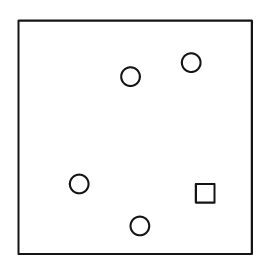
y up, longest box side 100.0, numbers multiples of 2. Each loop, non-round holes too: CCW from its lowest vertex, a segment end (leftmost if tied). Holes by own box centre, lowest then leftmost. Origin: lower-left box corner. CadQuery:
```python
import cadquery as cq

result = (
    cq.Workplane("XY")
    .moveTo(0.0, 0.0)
    .lineTo(100.0, 0.0)
    .lineTo(100.0, 100.0)
    .lineTo(0.0, 100.0)
    .close()
    .moveTo(52.0, 12.0)
    .circle(4.0)
    .moveTo(76.0, 22.0)
    .lineTo(84.0, 22.0)
    .lineTo(84.0, 30.0)
    .lineTo(76.0, 30.0)
    .close()
    .moveTo(26.0, 30.0)
    .circle(4.0)
    .moveTo(48.0, 76.0)
    .circle(4.0)
    .moveTo(74.0, 82.0)
    .circle(4.0)
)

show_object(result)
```